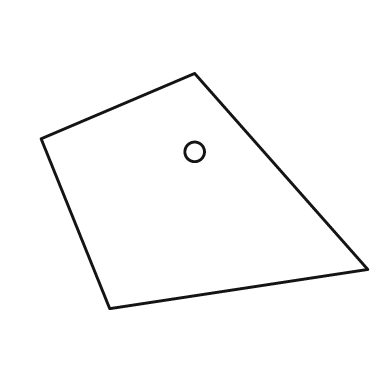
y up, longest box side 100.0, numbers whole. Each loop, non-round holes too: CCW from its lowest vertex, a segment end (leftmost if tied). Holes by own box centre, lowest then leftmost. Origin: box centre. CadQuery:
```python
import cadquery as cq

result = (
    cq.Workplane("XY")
    .moveTo(-29.0, -36.0)
    .lineTo(50.0, -24.0)
    .lineTo(-3.0, 36.0)
    .lineTo(-50.0, 16.0)
    .close()
    .moveTo(-3.0, 12.0)
    .circle(3.0)
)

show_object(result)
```